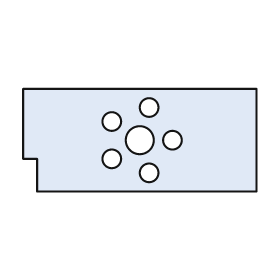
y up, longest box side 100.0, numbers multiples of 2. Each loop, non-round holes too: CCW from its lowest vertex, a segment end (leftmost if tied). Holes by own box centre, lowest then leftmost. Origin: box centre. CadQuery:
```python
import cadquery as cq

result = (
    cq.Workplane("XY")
    .moveTo(-44.0, -22.0)
    .lineTo(50.0, -22.0)
    .lineTo(50.0, 22.0)
    .lineTo(-50.0, 22.0)
    .lineTo(-50.0, -8.0)
    .lineTo(-44.0, -8.0)
    .close()
    .moveTo(4.0, -14.0)
    .circle(4.0)
    .moveTo(-12.0, -8.0)
    .circle(4.0)
    .moveTo(0.0, 0.0)
    .circle(6.0)
    .moveTo(14.0, 0.0)
    .circle(4.0)
    .moveTo(-12.0, 8.0)
    .circle(4.0)
    .moveTo(4.0, 14.0)
    .circle(4.0)
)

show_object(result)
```